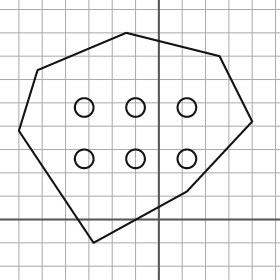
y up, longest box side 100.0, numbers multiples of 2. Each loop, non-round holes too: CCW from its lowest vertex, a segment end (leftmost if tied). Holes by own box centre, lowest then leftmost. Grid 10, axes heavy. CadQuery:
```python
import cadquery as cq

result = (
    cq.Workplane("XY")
    .moveTo(-28.0, -10.0)
    .lineTo(12.0, 12.0)
    .lineTo(40.0, 42.0)
    .lineTo(26.0, 70.0)
    .lineTo(-14.0, 80.0)
    .lineTo(-52.0, 64.0)
    .lineTo(-60.0, 38.0)
    .close()
    .moveTo(-32.0, 26.0)
    .circle(4.0)
    .moveTo(-10.0, 26.0)
    .circle(4.0)
    .moveTo(12.0, 26.0)
    .circle(4.0)
    .moveTo(-32.0, 48.0)
    .circle(4.0)
    .moveTo(-10.0, 48.0)
    .circle(4.0)
    .moveTo(12.0, 48.0)
    .circle(4.0)
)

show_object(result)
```